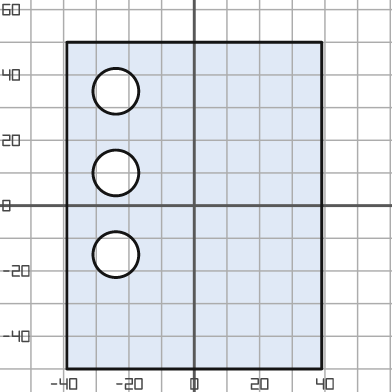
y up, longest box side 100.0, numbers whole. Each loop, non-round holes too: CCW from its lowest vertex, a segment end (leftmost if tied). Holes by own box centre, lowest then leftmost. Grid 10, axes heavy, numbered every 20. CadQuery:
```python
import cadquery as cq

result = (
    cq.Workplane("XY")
    .moveTo(-39.0, -50.0)
    .lineTo(39.0, -50.0)
    .lineTo(39.0, 50.0)
    .lineTo(-39.0, 50.0)
    .close()
    .moveTo(-24.0, -15.0)
    .circle(7.0)
    .moveTo(-24.0, 10.0)
    .circle(7.0)
    .moveTo(-24.0, 35.0)
    .circle(7.0)
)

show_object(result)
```